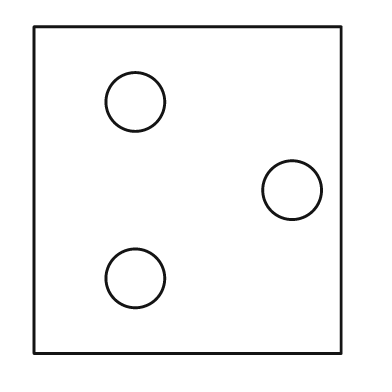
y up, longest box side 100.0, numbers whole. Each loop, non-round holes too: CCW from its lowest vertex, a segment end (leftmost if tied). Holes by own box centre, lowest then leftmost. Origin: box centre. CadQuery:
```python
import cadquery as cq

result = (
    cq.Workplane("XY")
    .moveTo(-47.0, -50.0)
    .lineTo(47.0, -50.0)
    .lineTo(47.0, 50.0)
    .lineTo(-47.0, 50.0)
    .close()
    .moveTo(-16.0, -27.0)
    .circle(9.0)
    .moveTo(32.0, 0.0)
    .circle(9.0)
    .moveTo(-16.0, 27.0)
    .circle(9.0)
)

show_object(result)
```